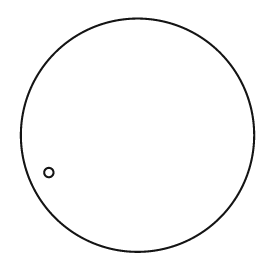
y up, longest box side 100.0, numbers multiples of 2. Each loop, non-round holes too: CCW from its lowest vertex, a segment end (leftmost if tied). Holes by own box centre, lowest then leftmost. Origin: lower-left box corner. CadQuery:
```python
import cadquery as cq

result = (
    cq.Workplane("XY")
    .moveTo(50.0, 50.0)
    .circle(50.0)
    .moveTo(12.0, 34.0)
    .circle(2.0)
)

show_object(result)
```